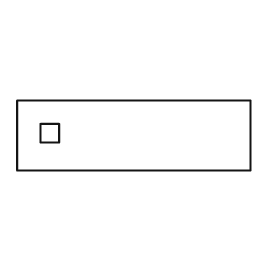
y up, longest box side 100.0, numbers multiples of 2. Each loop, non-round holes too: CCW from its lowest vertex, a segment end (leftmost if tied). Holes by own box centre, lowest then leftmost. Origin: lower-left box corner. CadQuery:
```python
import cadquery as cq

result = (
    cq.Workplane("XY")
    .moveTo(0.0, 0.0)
    .lineTo(100.0, 0.0)
    .lineTo(100.0, 30.0)
    .lineTo(0.0, 30.0)
    .close()
    .moveTo(10.0, 12.0)
    .lineTo(18.0, 12.0)
    .lineTo(18.0, 20.0)
    .lineTo(10.0, 20.0)
    .close()
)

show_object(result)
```